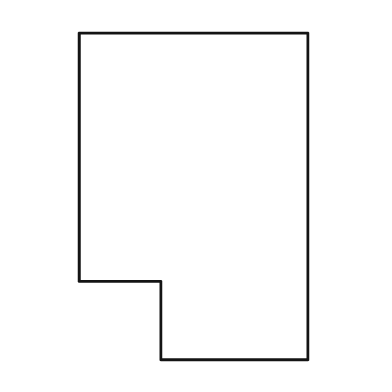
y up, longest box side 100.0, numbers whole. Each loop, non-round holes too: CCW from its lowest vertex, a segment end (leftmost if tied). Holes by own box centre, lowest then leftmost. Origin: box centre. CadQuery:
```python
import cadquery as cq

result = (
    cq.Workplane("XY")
    .moveTo(-10.0, -50.0)
    .lineTo(35.0, -50.0)
    .lineTo(35.0, 50.0)
    .lineTo(-35.0, 50.0)
    .lineTo(-35.0, -26.0)
    .lineTo(-10.0, -26.0)
    .close()
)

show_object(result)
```